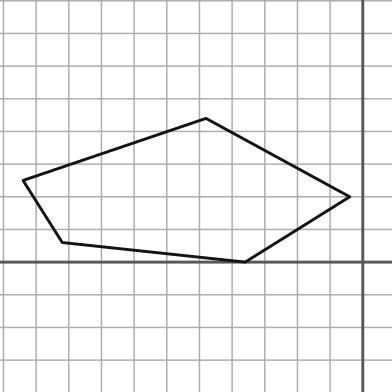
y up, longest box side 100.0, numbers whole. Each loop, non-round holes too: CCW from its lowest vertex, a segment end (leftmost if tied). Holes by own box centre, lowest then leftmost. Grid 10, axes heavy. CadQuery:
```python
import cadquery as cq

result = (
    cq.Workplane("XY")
    .moveTo(-36.0, 0.0)
    .lineTo(-4.0, 20.0)
    .lineTo(-48.0, 44.0)
    .lineTo(-104.0, 25.0)
    .lineTo(-92.0, 6.0)
    .close()
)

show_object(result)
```